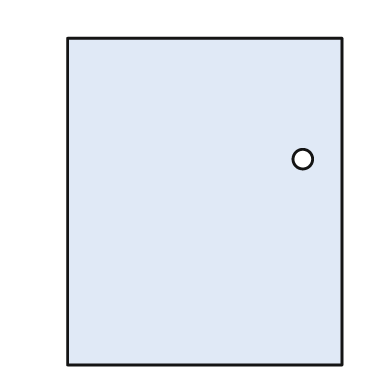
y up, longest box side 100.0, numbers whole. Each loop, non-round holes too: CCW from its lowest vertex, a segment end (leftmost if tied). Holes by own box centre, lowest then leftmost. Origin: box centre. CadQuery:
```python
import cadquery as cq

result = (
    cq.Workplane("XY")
    .moveTo(-42.0, -50.0)
    .lineTo(42.0, -50.0)
    .lineTo(42.0, 50.0)
    .lineTo(-42.0, 50.0)
    .close()
    .moveTo(30.0, 13.0)
    .circle(3.0)
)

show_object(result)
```